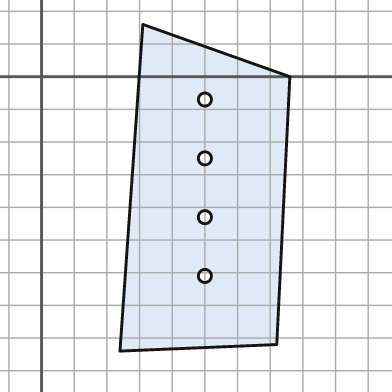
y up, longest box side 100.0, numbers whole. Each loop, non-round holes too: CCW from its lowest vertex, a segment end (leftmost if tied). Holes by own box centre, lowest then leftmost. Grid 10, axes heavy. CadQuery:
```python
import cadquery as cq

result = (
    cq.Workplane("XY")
    .moveTo(24.0, -84.0)
    .lineTo(72.0, -82.0)
    .lineTo(76.0, 0.0)
    .lineTo(31.0, 16.0)
    .close()
    .moveTo(50.0, -61.0)
    .circle(2.0)
    .moveTo(50.0, -43.0)
    .circle(2.0)
    .moveTo(50.0, -25.0)
    .circle(2.0)
    .moveTo(50.0, -7.0)
    .circle(2.0)
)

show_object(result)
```